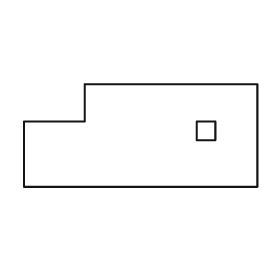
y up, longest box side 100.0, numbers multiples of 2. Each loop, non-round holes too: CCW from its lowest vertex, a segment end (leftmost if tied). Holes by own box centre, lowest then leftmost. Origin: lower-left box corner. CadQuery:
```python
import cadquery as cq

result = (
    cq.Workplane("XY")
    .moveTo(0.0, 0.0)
    .lineTo(100.0, 0.0)
    .lineTo(100.0, 44.0)
    .lineTo(26.0, 44.0)
    .lineTo(26.0, 28.0)
    .lineTo(0.0, 28.0)
    .close()
    .moveTo(74.0, 20.0)
    .lineTo(82.0, 20.0)
    .lineTo(82.0, 28.0)
    .lineTo(74.0, 28.0)
    .close()
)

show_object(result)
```